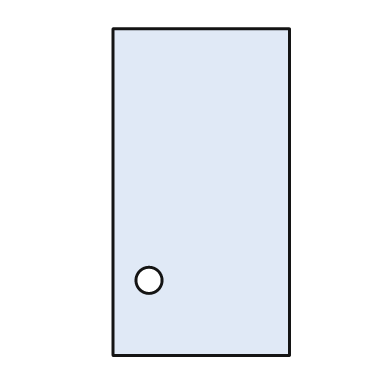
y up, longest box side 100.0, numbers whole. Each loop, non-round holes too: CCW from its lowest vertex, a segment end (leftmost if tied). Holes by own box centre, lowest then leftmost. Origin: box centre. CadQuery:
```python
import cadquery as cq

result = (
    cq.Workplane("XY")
    .moveTo(-27.0, -50.0)
    .lineTo(27.0, -50.0)
    .lineTo(27.0, 50.0)
    .lineTo(-27.0, 50.0)
    .close()
    .moveTo(-16.0, -27.0)
    .circle(4.0)
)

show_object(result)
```